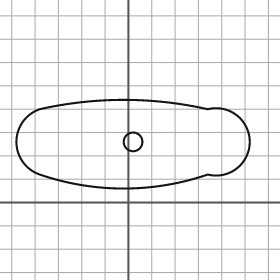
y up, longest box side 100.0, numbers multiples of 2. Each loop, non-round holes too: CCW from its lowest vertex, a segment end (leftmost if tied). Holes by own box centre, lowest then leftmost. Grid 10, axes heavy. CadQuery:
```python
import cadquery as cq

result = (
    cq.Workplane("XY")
    .moveTo(-38.0, 12.0)
    .threePointArc((-2.0, 6.0), (34.0, 12.0))
    .threePointArc((52.0, 26.0), (34.0, 40.0))
    .threePointArc((-2.0, 44.0), (-38.0, 40.0))
    .threePointArc((-48.0, 26.0), (-38.0, 12.0))
    .close()
    .moveTo(2.0, 26.0)
    .circle(4.0)
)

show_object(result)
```